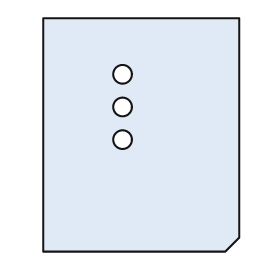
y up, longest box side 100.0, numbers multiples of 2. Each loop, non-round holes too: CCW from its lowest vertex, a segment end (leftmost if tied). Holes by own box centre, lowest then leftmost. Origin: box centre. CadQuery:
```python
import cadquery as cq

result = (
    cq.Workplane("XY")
    .moveTo(-42.0, -50.0)
    .lineTo(36.0, -50.0)
    .lineTo(42.0, -44.0)
    .lineTo(42.0, 50.0)
    .lineTo(-42.0, 50.0)
    .close()
    .moveTo(-8.0, -2.0)
    .circle(4.0)
    .moveTo(-8.0, 12.0)
    .circle(4.0)
    .moveTo(-8.0, 26.0)
    .circle(4.0)
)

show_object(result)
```